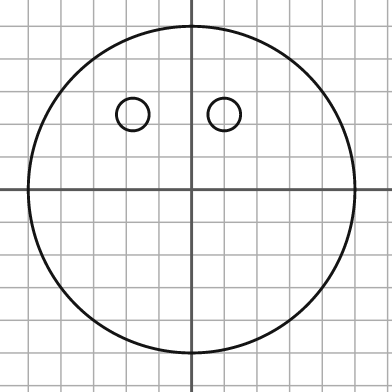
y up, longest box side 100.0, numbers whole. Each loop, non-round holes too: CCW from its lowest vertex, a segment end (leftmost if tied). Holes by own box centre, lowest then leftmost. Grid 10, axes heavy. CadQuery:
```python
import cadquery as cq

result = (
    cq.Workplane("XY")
    .moveTo(0.0, 0.0)
    .circle(50.0)
    .moveTo(-18.0, 23.0)
    .circle(5.0)
    .moveTo(10.0, 23.0)
    .circle(5.0)
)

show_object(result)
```